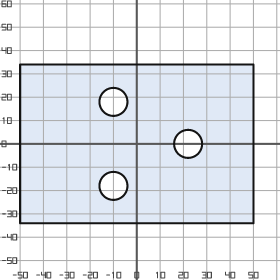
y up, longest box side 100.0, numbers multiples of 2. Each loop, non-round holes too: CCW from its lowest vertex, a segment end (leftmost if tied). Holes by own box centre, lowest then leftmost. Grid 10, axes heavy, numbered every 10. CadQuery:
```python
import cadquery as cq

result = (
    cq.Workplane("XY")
    .moveTo(-50.0, -34.0)
    .lineTo(50.0, -34.0)
    .lineTo(50.0, 34.0)
    .lineTo(-50.0, 34.0)
    .close()
    .moveTo(-10.0, -18.0)
    .circle(6.0)
    .moveTo(22.0, 0.0)
    .circle(6.0)
    .moveTo(-10.0, 18.0)
    .circle(6.0)
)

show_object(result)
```